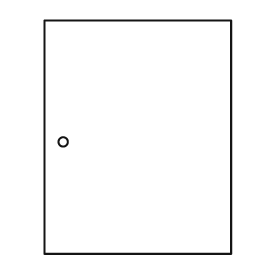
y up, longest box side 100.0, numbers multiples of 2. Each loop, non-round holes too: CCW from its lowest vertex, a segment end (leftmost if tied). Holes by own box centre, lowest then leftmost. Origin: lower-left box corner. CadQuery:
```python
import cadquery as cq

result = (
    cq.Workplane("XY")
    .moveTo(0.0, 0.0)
    .lineTo(80.0, 0.0)
    .lineTo(80.0, 100.0)
    .lineTo(0.0, 100.0)
    .close()
    .moveTo(8.0, 48.0)
    .circle(2.0)
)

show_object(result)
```